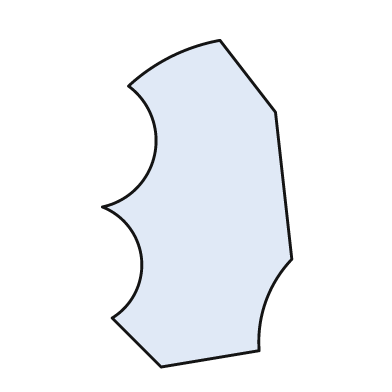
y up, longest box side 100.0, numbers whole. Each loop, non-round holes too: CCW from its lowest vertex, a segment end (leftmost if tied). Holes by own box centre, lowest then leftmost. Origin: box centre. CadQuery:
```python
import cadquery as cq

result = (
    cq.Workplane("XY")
    .moveTo(-11.0, -50.0)
    .lineTo(19.0, -45.0)
    .threePointArc((21.0, -30.0), (29.0, -17.0))
    .lineTo(24.0, 28.0)
    .lineTo(7.0, 50.0)
    .threePointArc((-8.0, 45.0), (-21.0, 36.0))
    .threePointArc((-13.0, 15.0), (-29.0, -1.0))
    .threePointArc((-17.0, -17.0), (-26.0, -35.0))
    .close()
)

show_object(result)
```